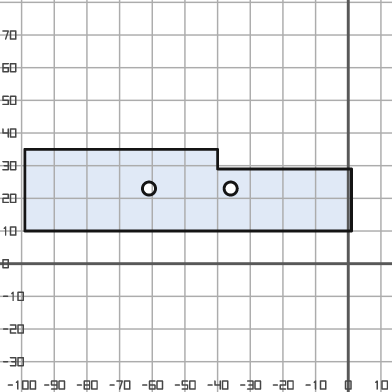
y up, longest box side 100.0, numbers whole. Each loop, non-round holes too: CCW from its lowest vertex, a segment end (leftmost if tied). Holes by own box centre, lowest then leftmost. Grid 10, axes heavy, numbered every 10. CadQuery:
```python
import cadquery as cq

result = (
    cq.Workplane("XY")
    .moveTo(-99.0, 10.0)
    .lineTo(1.0, 10.0)
    .lineTo(1.0, 29.0)
    .lineTo(-40.0, 29.0)
    .lineTo(-40.0, 35.0)
    .lineTo(-99.0, 35.0)
    .close()
    .moveTo(-61.0, 23.0)
    .circle(2.0)
    .moveTo(-36.0, 23.0)
    .circle(2.0)
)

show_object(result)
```